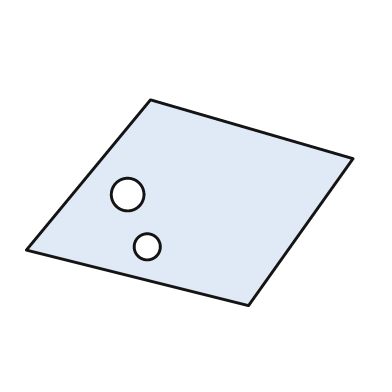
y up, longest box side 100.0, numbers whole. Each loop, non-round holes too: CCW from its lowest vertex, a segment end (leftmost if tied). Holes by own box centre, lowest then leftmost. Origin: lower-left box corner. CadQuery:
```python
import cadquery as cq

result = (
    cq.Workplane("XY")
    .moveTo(68.0, 0.0)
    .lineTo(100.0, 45.0)
    .lineTo(38.0, 63.0)
    .lineTo(0.0, 17.0)
    .close()
    .moveTo(37.0, 18.0)
    .circle(4.0)
    .moveTo(31.0, 34.0)
    .circle(5.0)
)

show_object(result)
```